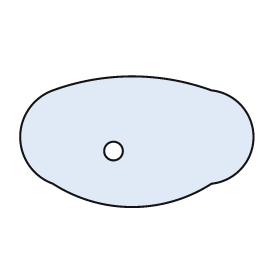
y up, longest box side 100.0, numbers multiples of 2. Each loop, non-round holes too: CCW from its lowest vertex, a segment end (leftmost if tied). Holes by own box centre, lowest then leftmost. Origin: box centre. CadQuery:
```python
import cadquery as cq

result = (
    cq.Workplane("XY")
    .moveTo(-36.0, -18.0)
    .threePointArc((-2.0, -28.0), (32.0, -18.0))
    .threePointArc((50.0, 2.0), (32.0, 22.0))
    .threePointArc((-2.0, 28.0), (-36.0, 22.0))
    .threePointArc((-50.0, 2.0), (-36.0, -18.0))
    .close()
    .moveTo(-10.0, -4.0)
    .circle(4.0)
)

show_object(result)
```